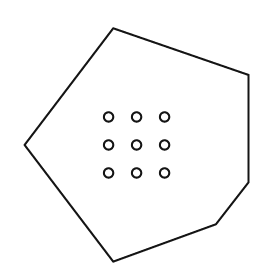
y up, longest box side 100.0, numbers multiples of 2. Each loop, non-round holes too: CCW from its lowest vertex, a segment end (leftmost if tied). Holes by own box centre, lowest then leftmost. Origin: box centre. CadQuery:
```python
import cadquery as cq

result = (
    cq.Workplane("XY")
    .moveTo(-10.0, -50.0)
    .lineTo(34.0, -34.0)
    .lineTo(48.0, -16.0)
    .lineTo(48.0, 30.0)
    .lineTo(-10.0, 50.0)
    .lineTo(-48.0, 0.0)
    .close()
    .moveTo(-12.0, -12.0)
    .circle(2.0)
    .moveTo(0.0, -12.0)
    .circle(2.0)
    .moveTo(12.0, -12.0)
    .circle(2.0)
    .moveTo(-12.0, 0.0)
    .circle(2.0)
    .moveTo(0.0, 0.0)
    .circle(2.0)
    .moveTo(12.0, 0.0)
    .circle(2.0)
    .moveTo(-12.0, 12.0)
    .circle(2.0)
    .moveTo(0.0, 12.0)
    .circle(2.0)
    .moveTo(12.0, 12.0)
    .circle(2.0)
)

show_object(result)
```